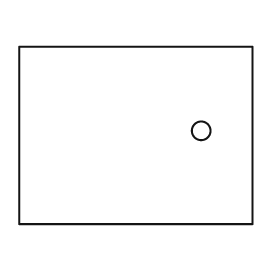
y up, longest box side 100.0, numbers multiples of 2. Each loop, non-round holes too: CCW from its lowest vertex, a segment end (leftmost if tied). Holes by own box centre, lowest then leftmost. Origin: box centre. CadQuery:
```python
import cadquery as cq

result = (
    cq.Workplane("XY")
    .moveTo(-50.0, -38.0)
    .lineTo(50.0, -38.0)
    .lineTo(50.0, 38.0)
    .lineTo(-50.0, 38.0)
    .close()
    .moveTo(28.0, 2.0)
    .circle(4.0)
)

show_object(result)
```